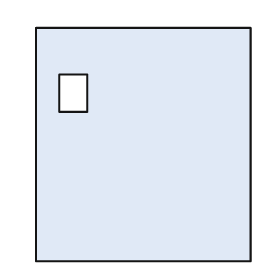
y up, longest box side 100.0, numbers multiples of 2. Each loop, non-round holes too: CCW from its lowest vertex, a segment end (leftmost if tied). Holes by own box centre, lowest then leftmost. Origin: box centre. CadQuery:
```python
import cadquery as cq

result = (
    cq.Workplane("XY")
    .moveTo(-46.0, -50.0)
    .lineTo(46.0, -50.0)
    .lineTo(46.0, 50.0)
    .lineTo(-46.0, 50.0)
    .close()
    .moveTo(-36.0, 14.0)
    .lineTo(-24.0, 14.0)
    .lineTo(-24.0, 30.0)
    .lineTo(-36.0, 30.0)
    .close()
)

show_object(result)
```